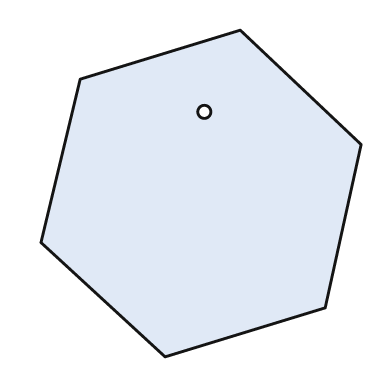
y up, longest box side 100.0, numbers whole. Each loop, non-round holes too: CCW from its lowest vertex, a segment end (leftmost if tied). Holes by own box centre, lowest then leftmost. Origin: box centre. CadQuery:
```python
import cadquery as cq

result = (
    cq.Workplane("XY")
    .moveTo(-11.0, -50.0)
    .lineTo(38.0, -35.0)
    .lineTo(49.0, 15.0)
    .lineTo(12.0, 50.0)
    .lineTo(-37.0, 35.0)
    .lineTo(-49.0, -15.0)
    .close()
    .moveTo(1.0, 25.0)
    .circle(2.0)
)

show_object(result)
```